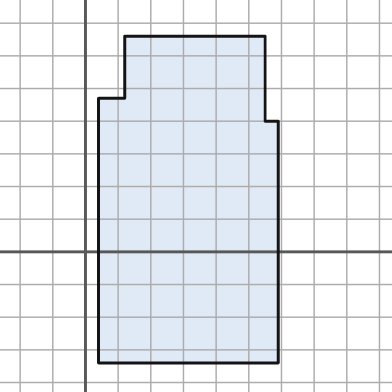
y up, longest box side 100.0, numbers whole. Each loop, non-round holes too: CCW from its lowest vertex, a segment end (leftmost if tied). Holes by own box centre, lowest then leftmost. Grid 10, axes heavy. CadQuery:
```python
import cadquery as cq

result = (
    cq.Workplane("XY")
    .moveTo(4.0, -34.0)
    .lineTo(59.0, -34.0)
    .lineTo(59.0, 40.0)
    .lineTo(55.0, 40.0)
    .lineTo(55.0, 66.0)
    .lineTo(12.0, 66.0)
    .lineTo(12.0, 47.0)
    .lineTo(4.0, 47.0)
    .close()
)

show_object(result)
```